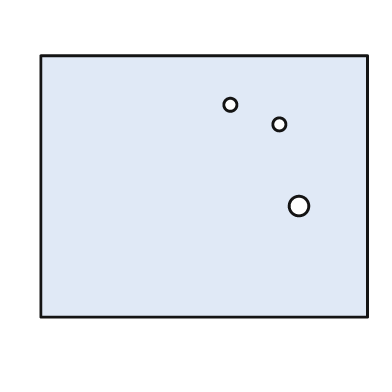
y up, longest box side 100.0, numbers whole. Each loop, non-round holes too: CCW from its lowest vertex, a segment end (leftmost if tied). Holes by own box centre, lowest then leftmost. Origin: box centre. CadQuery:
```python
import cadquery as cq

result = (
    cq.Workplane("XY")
    .moveTo(-50.0, -40.0)
    .lineTo(50.0, -40.0)
    .lineTo(50.0, 40.0)
    .lineTo(-50.0, 40.0)
    .close()
    .moveTo(29.0, -6.0)
    .circle(3.0)
    .moveTo(23.0, 19.0)
    .circle(2.0)
    .moveTo(8.0, 25.0)
    .circle(2.0)
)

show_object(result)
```